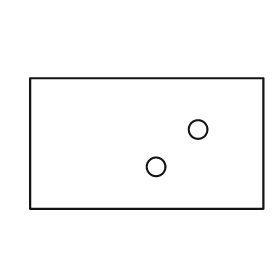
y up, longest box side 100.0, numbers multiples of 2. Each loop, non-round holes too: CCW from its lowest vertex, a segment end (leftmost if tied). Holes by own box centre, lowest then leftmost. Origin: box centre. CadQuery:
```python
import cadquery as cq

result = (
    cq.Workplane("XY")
    .moveTo(-50.0, -28.0)
    .lineTo(50.0, -28.0)
    .lineTo(50.0, 28.0)
    .lineTo(-50.0, 28.0)
    .close()
    .moveTo(4.0, -10.0)
    .circle(4.0)
    .moveTo(22.0, 6.0)
    .circle(4.0)
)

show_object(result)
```